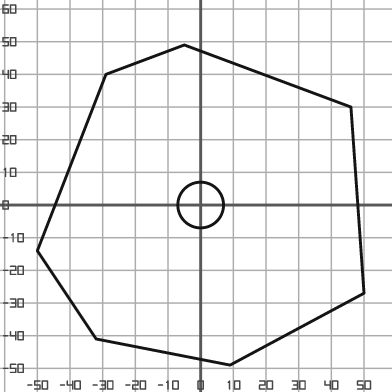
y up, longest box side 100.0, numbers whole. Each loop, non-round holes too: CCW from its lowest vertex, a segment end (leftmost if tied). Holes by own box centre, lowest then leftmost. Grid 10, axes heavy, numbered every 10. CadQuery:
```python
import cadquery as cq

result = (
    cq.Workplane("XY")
    .moveTo(9.0, -49.0)
    .lineTo(50.0, -27.0)
    .lineTo(46.0, 30.0)
    .lineTo(-5.0, 49.0)
    .lineTo(-29.0, 40.0)
    .lineTo(-50.0, -14.0)
    .lineTo(-32.0, -41.0)
    .close()
    .moveTo(0.0, 0.0)
    .circle(7.0)
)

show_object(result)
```